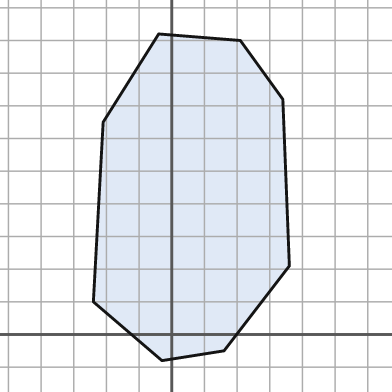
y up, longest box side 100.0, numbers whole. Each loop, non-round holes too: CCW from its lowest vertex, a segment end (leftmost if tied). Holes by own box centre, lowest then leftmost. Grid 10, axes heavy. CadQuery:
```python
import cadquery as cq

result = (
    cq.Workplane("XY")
    .moveTo(-3.0, -8.0)
    .lineTo(16.0, -5.0)
    .lineTo(36.0, 21.0)
    .lineTo(34.0, 72.0)
    .lineTo(21.0, 90.0)
    .lineTo(-4.0, 92.0)
    .lineTo(-21.0, 65.0)
    .lineTo(-24.0, 10.0)
    .close()
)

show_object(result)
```